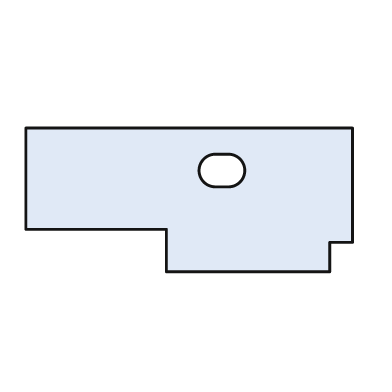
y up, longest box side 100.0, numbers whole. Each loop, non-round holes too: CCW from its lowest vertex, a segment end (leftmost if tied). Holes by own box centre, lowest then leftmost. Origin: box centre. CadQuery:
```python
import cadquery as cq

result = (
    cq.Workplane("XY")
    .moveTo(-7.0, -22.0)
    .lineTo(43.0, -22.0)
    .lineTo(43.0, -13.0)
    .lineTo(50.0, -13.0)
    .lineTo(50.0, 22.0)
    .lineTo(-50.0, 22.0)
    .lineTo(-50.0, -9.0)
    .lineTo(-7.0, -9.0)
    .close()
    .moveTo(8.0, 4.0)
    .lineTo(12.0, 4.0)
    .threePointArc((17.0, 9.0), (12.0, 14.0))
    .lineTo(8.0, 14.0)
    .threePointArc((3.0, 9.0), (8.0, 4.0))
    .close()
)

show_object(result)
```